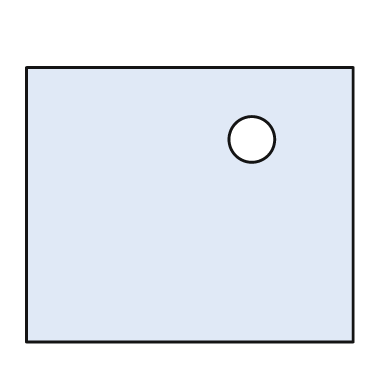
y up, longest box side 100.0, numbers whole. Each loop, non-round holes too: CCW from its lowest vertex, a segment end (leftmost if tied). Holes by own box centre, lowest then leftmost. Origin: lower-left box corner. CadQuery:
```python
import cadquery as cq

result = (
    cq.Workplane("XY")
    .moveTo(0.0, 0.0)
    .lineTo(100.0, 0.0)
    .lineTo(100.0, 84.0)
    .lineTo(0.0, 84.0)
    .close()
    .moveTo(69.0, 62.0)
    .circle(7.0)
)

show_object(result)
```